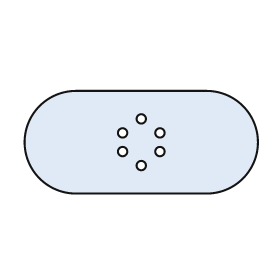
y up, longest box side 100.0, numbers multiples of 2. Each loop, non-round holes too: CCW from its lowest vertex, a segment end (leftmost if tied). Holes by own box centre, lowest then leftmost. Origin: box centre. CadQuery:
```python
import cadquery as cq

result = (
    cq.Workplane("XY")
    .moveTo(-28.0, -22.0)
    .lineTo(28.0, -22.0)
    .threePointArc((50.0, 0.0), (28.0, 22.0))
    .lineTo(-28.0, 22.0)
    .threePointArc((-50.0, 0.0), (-28.0, -22.0))
    .close()
    .moveTo(0.0, -10.0)
    .circle(2.0)
    .moveTo(-8.0, -4.0)
    .circle(2.0)
    .moveTo(8.0, -4.0)
    .circle(2.0)
    .moveTo(-8.0, 4.0)
    .circle(2.0)
    .moveTo(8.0, 4.0)
    .circle(2.0)
    .moveTo(0.0, 10.0)
    .circle(2.0)
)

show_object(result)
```